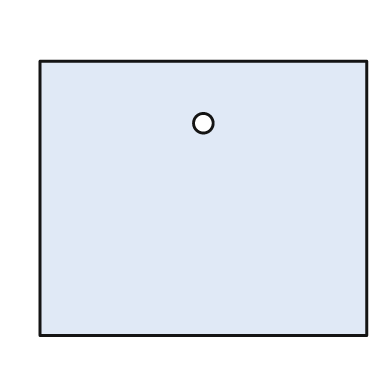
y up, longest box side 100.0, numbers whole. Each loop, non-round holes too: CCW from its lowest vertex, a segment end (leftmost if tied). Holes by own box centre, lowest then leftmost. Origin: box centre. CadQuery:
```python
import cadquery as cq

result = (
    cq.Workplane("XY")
    .moveTo(-50.0, -42.0)
    .lineTo(50.0, -42.0)
    .lineTo(50.0, 42.0)
    .lineTo(-50.0, 42.0)
    .close()
    .moveTo(0.0, 23.0)
    .circle(3.0)
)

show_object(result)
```